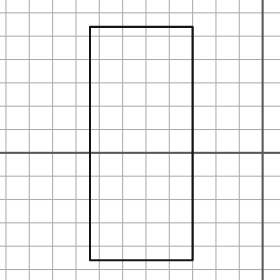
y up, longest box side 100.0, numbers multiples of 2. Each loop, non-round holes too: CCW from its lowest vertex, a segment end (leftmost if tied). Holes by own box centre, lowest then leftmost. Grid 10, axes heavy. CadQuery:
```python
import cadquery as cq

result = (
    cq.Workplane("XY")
    .moveTo(-74.0, -46.0)
    .lineTo(-30.0, -46.0)
    .lineTo(-30.0, 54.0)
    .lineTo(-74.0, 54.0)
    .close()
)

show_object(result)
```